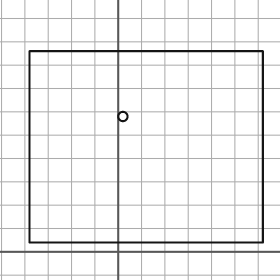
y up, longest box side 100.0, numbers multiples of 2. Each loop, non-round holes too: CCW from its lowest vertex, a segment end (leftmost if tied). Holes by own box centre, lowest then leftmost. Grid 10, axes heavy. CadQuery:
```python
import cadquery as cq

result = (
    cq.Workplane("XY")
    .moveTo(-38.0, 4.0)
    .lineTo(62.0, 4.0)
    .lineTo(62.0, 86.0)
    .lineTo(-38.0, 86.0)
    .close()
    .moveTo(2.0, 58.0)
    .circle(2.0)
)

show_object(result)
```